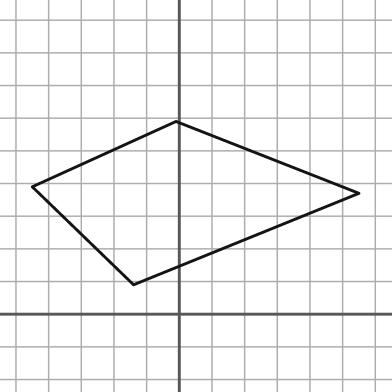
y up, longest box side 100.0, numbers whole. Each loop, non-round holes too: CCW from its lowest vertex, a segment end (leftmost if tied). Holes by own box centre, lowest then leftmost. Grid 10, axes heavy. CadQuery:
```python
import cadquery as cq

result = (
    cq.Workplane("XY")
    .moveTo(-14.0, 9.0)
    .lineTo(55.0, 37.0)
    .lineTo(-1.0, 59.0)
    .lineTo(-45.0, 39.0)
    .close()
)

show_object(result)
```